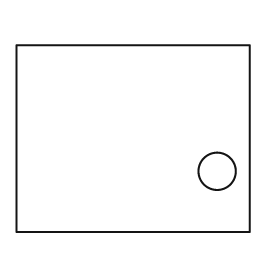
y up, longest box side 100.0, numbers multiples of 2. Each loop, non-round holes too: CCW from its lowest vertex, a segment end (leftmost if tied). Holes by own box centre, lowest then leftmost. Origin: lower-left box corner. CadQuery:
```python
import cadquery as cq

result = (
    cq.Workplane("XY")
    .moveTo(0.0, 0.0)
    .lineTo(100.0, 0.0)
    .lineTo(100.0, 80.0)
    .lineTo(0.0, 80.0)
    .close()
    .moveTo(86.0, 26.0)
    .circle(8.0)
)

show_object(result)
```